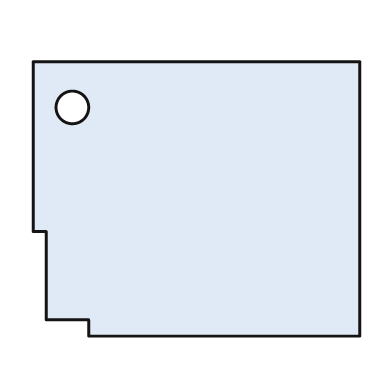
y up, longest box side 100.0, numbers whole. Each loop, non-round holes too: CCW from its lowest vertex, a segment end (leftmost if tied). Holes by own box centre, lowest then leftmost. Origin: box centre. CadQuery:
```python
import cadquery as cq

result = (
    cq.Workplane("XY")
    .moveTo(-33.0, -42.0)
    .lineTo(50.0, -42.0)
    .lineTo(50.0, 42.0)
    .lineTo(-50.0, 42.0)
    .lineTo(-50.0, -10.0)
    .lineTo(-46.0, -10.0)
    .lineTo(-46.0, -37.0)
    .lineTo(-33.0, -37.0)
    .close()
    .moveTo(-38.0, 28.0)
    .circle(5.0)
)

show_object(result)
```